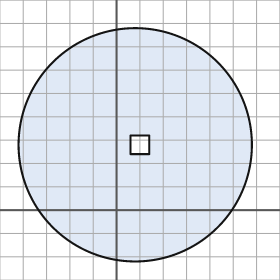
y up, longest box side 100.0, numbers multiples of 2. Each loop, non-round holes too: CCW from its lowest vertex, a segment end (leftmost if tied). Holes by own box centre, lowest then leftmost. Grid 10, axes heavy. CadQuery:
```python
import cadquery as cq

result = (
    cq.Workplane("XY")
    .moveTo(8.0, 28.0)
    .circle(50.0)
    .moveTo(6.0, 24.0)
    .lineTo(14.0, 24.0)
    .lineTo(14.0, 32.0)
    .lineTo(6.0, 32.0)
    .close()
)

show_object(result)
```